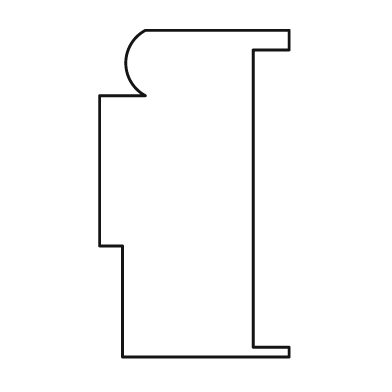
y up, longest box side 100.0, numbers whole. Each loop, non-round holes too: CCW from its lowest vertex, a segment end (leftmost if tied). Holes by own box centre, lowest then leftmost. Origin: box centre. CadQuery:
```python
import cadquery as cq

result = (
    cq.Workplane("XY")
    .moveTo(-22.0, -50.0)
    .lineTo(29.0, -50.0)
    .lineTo(29.0, -47.0)
    .lineTo(18.0, -47.0)
    .lineTo(18.0, 44.0)
    .lineTo(29.0, 44.0)
    .lineTo(29.0, 50.0)
    .lineTo(-15.0, 50.0)
    .threePointArc((-21.0, 40.0), (-15.0, 30.0))
    .lineTo(-29.0, 30.0)
    .lineTo(-29.0, -16.0)
    .lineTo(-22.0, -16.0)
    .close()
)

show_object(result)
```